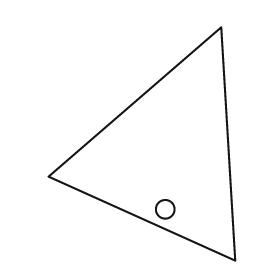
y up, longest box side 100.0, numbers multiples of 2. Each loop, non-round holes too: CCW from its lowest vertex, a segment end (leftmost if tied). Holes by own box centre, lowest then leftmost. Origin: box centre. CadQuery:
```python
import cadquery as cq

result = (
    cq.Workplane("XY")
    .moveTo(40.0, -50.0)
    .lineTo(34.0, 50.0)
    .lineTo(-40.0, -14.0)
    .close()
    .moveTo(10.0, -28.0)
    .circle(4.0)
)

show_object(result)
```